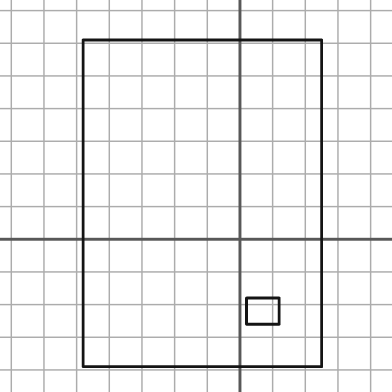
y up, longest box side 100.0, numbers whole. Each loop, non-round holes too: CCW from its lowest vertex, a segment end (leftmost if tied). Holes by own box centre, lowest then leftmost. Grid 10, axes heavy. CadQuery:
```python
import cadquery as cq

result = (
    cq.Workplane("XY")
    .moveTo(-48.0, -39.0)
    .lineTo(25.0, -39.0)
    .lineTo(25.0, 61.0)
    .lineTo(-48.0, 61.0)
    .close()
    .moveTo(2.0, -26.0)
    .lineTo(12.0, -26.0)
    .lineTo(12.0, -18.0)
    .lineTo(2.0, -18.0)
    .close()
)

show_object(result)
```